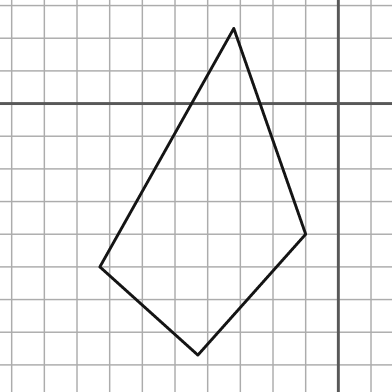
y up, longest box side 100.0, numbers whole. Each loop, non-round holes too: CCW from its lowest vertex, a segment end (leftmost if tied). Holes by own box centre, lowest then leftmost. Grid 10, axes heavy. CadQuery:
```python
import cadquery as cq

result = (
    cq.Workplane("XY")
    .moveTo(-43.0, -77.0)
    .lineTo(-10.0, -40.0)
    .lineTo(-32.0, 23.0)
    .lineTo(-73.0, -50.0)
    .close()
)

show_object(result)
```